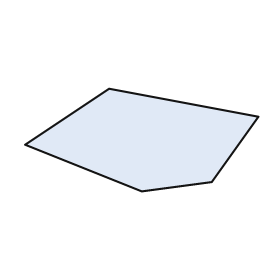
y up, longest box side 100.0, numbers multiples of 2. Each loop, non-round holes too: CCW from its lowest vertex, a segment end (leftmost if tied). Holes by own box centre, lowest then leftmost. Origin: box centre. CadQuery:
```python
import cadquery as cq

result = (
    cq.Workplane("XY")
    .moveTo(0.0, -22.0)
    .lineTo(30.0, -18.0)
    .lineTo(50.0, 10.0)
    .lineTo(-14.0, 22.0)
    .lineTo(-50.0, -2.0)
    .close()
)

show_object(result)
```